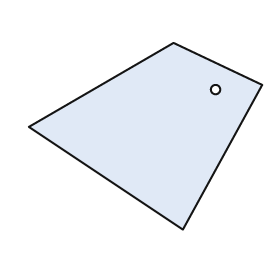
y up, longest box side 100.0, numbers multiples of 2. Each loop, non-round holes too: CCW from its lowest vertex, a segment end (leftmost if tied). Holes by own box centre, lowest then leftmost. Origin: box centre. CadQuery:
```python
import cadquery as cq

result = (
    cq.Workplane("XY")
    .moveTo(16.0, -40.0)
    .lineTo(50.0, 22.0)
    .lineTo(12.0, 40.0)
    .lineTo(-50.0, 4.0)
    .close()
    .moveTo(30.0, 20.0)
    .circle(2.0)
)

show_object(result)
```